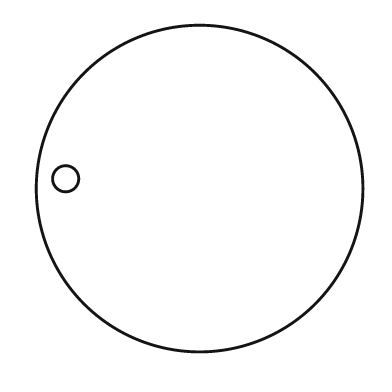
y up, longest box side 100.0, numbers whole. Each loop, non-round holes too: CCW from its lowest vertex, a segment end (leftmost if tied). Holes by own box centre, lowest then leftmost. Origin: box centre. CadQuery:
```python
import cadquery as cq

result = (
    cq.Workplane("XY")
    .moveTo(0.0, 0.0)
    .circle(50.0)
    .moveTo(-41.0, 3.0)
    .circle(4.0)
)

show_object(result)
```